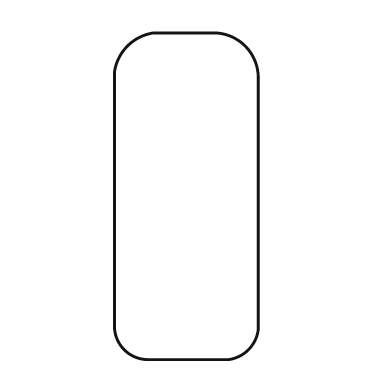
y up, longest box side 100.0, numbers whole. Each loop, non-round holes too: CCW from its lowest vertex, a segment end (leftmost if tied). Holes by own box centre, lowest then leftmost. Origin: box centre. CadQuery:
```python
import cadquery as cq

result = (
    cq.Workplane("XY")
    .moveTo(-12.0, -50.0)
    .lineTo(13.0, -50.0)
    .threePointArc((19.0, -47.0), (22.0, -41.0))
    .lineTo(22.0, 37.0)
    .threePointArc((18.0, 46.0), (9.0, 50.0))
    .lineTo(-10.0, 50.0)
    .threePointArc((-18.0, 46.0), (-22.0, 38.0))
    .lineTo(-22.0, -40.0)
    .threePointArc((-19.0, -47.0), (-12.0, -50.0))
    .close()
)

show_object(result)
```